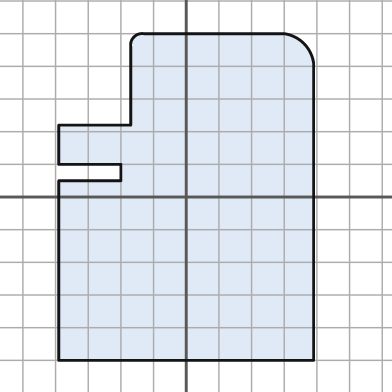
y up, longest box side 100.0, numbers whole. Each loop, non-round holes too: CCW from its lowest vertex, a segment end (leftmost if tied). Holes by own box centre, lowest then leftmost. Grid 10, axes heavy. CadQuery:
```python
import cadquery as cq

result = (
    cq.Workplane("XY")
    .moveTo(-39.0, -50.0)
    .lineTo(39.0, -50.0)
    .lineTo(39.0, 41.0)
    .threePointArc((36.0, 47.0), (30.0, 50.0))
    .lineTo(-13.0, 50.0)
    .threePointArc((-16.0, 49.0), (-17.0, 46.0))
    .lineTo(-17.0, 22.0)
    .lineTo(-39.0, 22.0)
    .lineTo(-39.0, 10.0)
    .lineTo(-20.0, 10.0)
    .lineTo(-20.0, 5.0)
    .lineTo(-39.0, 5.0)
    .close()
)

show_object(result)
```